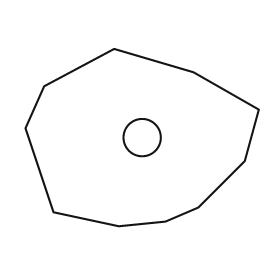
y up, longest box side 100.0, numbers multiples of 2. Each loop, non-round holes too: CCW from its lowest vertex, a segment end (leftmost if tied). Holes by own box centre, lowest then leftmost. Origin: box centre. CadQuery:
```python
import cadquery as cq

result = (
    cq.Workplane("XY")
    .moveTo(-10.0, -38.0)
    .lineTo(10.0, -36.0)
    .lineTo(24.0, -30.0)
    .lineTo(44.0, -10.0)
    .lineTo(50.0, 12.0)
    .lineTo(22.0, 28.0)
    .lineTo(-12.0, 38.0)
    .lineTo(-42.0, 22.0)
    .lineTo(-50.0, 4.0)
    .lineTo(-38.0, -32.0)
    .close()
    .moveTo(0.0, 0.0)
    .circle(8.0)
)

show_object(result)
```